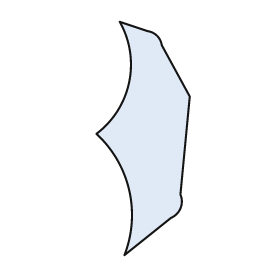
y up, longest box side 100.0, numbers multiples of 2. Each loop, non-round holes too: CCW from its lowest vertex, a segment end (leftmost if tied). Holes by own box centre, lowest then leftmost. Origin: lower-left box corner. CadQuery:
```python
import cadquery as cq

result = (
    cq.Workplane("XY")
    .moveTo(12.0, 0.0)
    .lineTo(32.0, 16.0)
    .threePointArc((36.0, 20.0), (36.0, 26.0))
    .lineTo(40.0, 68.0)
    .lineTo(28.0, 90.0)
    .threePointArc((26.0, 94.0), (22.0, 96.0))
    .lineTo(10.0, 100.0)
    .threePointArc((14.0, 74.0), (0.0, 52.0))
    .threePointArc((14.0, 28.0), (12.0, 0.0))
    .close()
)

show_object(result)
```